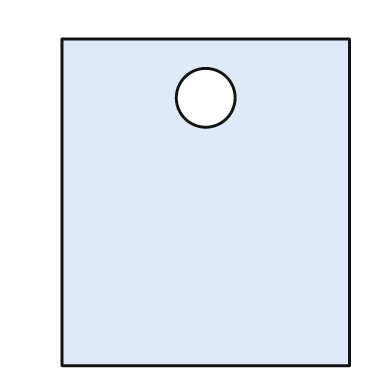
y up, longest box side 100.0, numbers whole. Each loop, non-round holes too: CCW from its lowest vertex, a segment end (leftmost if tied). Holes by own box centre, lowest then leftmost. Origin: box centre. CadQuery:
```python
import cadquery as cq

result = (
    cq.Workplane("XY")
    .moveTo(-44.0, -50.0)
    .lineTo(44.0, -50.0)
    .lineTo(44.0, 50.0)
    .lineTo(-44.0, 50.0)
    .close()
    .moveTo(0.0, 32.0)
    .circle(9.0)
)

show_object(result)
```